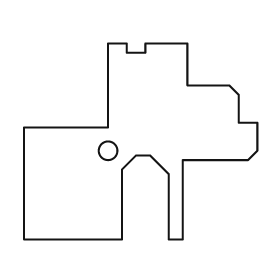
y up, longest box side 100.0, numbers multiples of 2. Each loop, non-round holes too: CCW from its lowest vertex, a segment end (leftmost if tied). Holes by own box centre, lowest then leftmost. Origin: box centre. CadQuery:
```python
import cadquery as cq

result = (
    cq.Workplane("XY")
    .moveTo(-50.0, -42.0)
    .lineTo(-8.0, -42.0)
    .lineTo(-8.0, -12.0)
    .lineTo(-2.0, -6.0)
    .lineTo(4.0, -6.0)
    .lineTo(12.0, -14.0)
    .lineTo(12.0, -42.0)
    .lineTo(18.0, -42.0)
    .lineTo(18.0, -8.0)
    .lineTo(46.0, -8.0)
    .lineTo(50.0, -4.0)
    .lineTo(50.0, 8.0)
    .lineTo(42.0, 8.0)
    .lineTo(42.0, 20.0)
    .lineTo(38.0, 24.0)
    .lineTo(20.0, 24.0)
    .lineTo(20.0, 42.0)
    .lineTo(2.0, 42.0)
    .lineTo(2.0, 38.0)
    .lineTo(-6.0, 38.0)
    .lineTo(-6.0, 42.0)
    .lineTo(-14.0, 42.0)
    .lineTo(-14.0, 6.0)
    .lineTo(-50.0, 6.0)
    .close()
    .moveTo(-14.0, -4.0)
    .circle(4.0)
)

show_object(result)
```